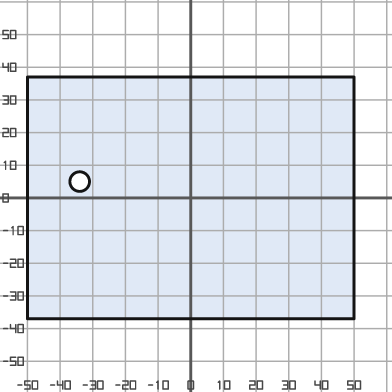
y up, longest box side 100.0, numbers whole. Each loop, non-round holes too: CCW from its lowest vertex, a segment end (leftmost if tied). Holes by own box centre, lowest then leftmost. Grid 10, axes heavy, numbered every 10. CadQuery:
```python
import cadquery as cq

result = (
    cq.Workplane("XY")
    .moveTo(-50.0, -37.0)
    .lineTo(50.0, -37.0)
    .lineTo(50.0, 37.0)
    .lineTo(-50.0, 37.0)
    .close()
    .moveTo(-34.0, 5.0)
    .circle(3.0)
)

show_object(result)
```